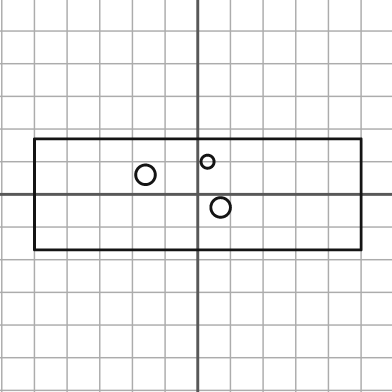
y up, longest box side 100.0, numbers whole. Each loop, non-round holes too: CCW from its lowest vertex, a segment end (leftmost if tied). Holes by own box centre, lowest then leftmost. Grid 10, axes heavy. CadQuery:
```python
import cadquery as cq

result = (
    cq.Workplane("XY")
    .moveTo(-50.0, -17.0)
    .lineTo(50.0, -17.0)
    .lineTo(50.0, 17.0)
    .lineTo(-50.0, 17.0)
    .close()
    .moveTo(7.0, -4.0)
    .circle(3.0)
    .moveTo(-16.0, 6.0)
    .circle(3.0)
    .moveTo(3.0, 10.0)
    .circle(2.0)
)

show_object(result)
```